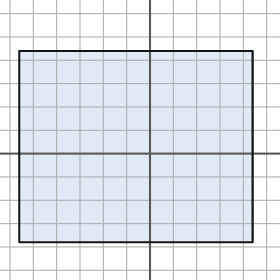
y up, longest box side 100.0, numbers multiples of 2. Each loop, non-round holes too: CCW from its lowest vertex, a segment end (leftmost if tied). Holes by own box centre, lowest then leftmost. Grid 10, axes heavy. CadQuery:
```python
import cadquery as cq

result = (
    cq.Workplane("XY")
    .moveTo(-56.0, -38.0)
    .lineTo(44.0, -38.0)
    .lineTo(44.0, 44.0)
    .lineTo(-56.0, 44.0)
    .close()
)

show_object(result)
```